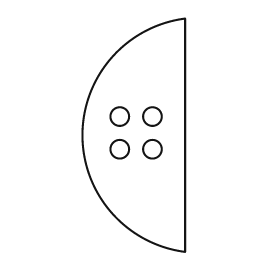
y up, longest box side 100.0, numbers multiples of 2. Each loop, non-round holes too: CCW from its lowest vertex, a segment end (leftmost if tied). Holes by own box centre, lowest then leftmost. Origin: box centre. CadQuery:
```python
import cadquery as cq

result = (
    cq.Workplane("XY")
    .moveTo(22.0, -50.0)
    .lineTo(22.0, 50.0)
    .threePointArc((-22.0, 0.0), (22.0, -50.0))
    .close()
    .moveTo(-6.0, -6.0)
    .circle(4.0)
    .moveTo(8.0, -6.0)
    .circle(4.0)
    .moveTo(-6.0, 8.0)
    .circle(4.0)
    .moveTo(8.0, 8.0)
    .circle(4.0)
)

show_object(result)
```